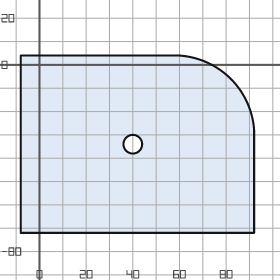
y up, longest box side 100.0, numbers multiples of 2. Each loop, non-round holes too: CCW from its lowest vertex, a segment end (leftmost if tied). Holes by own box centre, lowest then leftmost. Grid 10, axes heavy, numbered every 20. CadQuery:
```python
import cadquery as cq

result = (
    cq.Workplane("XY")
    .moveTo(-8.0, -72.0)
    .lineTo(92.0, -72.0)
    .lineTo(92.0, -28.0)
    .threePointArc((82.0, -6.0), (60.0, 4.0))
    .lineTo(-8.0, 4.0)
    .close()
    .moveTo(40.0, -34.0)
    .circle(4.0)
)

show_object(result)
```